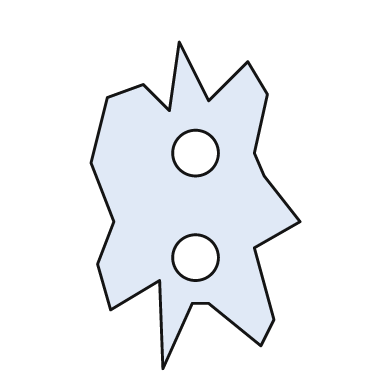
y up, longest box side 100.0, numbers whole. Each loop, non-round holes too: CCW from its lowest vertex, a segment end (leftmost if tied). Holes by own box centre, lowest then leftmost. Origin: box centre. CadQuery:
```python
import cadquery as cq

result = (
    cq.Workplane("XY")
    .moveTo(-10.0, -50.0)
    .lineTo(-1.0, -30.0)
    .lineTo(4.0, -30.0)
    .lineTo(20.0, -43.0)
    .lineTo(24.0, -35.0)
    .lineTo(18.0, -13.0)
    .lineTo(32.0, -5.0)
    .lineTo(21.0, 9.0)
    .lineTo(18.0, 16.0)
    .lineTo(22.0, 34.0)
    .lineTo(16.0, 44.0)
    .lineTo(4.0, 32.0)
    .lineTo(-5.0, 50.0)
    .lineTo(-8.0, 29.0)
    .lineTo(-16.0, 37.0)
    .lineTo(-27.0, 33.0)
    .lineTo(-32.0, 13.0)
    .lineTo(-25.0, -5.0)
    .lineTo(-30.0, -18.0)
    .lineTo(-26.0, -32.0)
    .lineTo(-11.0, -23.0)
    .close()
    .moveTo(0.0, -16.0)
    .circle(7.0)
    .moveTo(0.0, 16.0)
    .circle(7.0)
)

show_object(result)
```